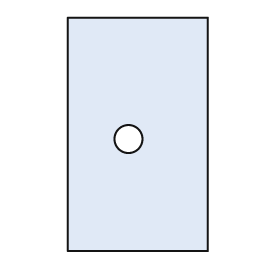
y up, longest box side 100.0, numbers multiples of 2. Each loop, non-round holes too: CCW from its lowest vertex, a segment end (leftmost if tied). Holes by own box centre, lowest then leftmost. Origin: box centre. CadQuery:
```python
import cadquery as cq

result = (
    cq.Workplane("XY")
    .moveTo(-30.0, -50.0)
    .lineTo(30.0, -50.0)
    .lineTo(30.0, 50.0)
    .lineTo(-30.0, 50.0)
    .close()
    .moveTo(-4.0, -2.0)
    .circle(6.0)
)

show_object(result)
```